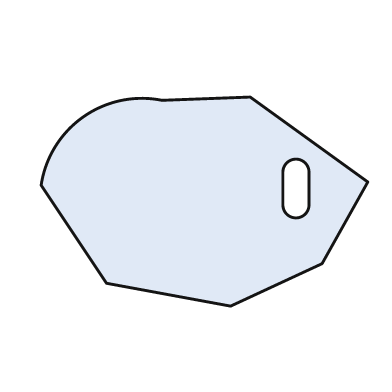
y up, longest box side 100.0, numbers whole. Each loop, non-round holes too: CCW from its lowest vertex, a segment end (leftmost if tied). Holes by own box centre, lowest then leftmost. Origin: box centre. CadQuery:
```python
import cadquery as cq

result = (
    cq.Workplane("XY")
    .moveTo(8.0, -32.0)
    .lineTo(36.0, -19.0)
    .lineTo(50.0, 6.0)
    .lineTo(14.0, 32.0)
    .lineTo(-13.0, 31.0)
    .threePointArc((-37.0, 26.0), (-50.0, 5.0))
    .lineTo(-30.0, -25.0)
    .close()
    .moveTo(24.0, -1.0)
    .threePointArc((28.0, -5.0), (32.0, -1.0))
    .lineTo(32.0, 9.0)
    .threePointArc((28.0, 13.0), (24.0, 9.0))
    .close()
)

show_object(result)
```